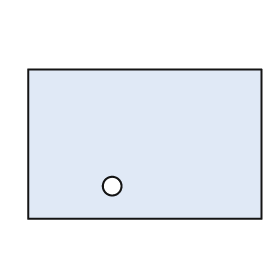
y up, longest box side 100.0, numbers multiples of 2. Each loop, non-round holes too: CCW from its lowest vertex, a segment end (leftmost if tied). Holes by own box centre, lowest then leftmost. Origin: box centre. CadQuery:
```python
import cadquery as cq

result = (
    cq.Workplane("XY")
    .moveTo(-50.0, -32.0)
    .lineTo(50.0, -32.0)
    .lineTo(50.0, 32.0)
    .lineTo(-50.0, 32.0)
    .close()
    .moveTo(-14.0, -18.0)
    .circle(4.0)
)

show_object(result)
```